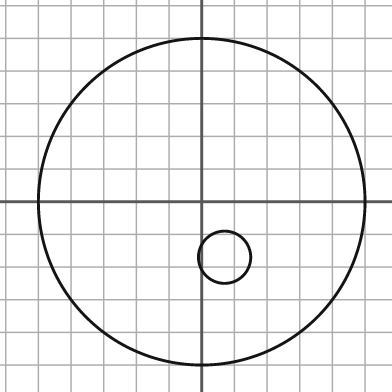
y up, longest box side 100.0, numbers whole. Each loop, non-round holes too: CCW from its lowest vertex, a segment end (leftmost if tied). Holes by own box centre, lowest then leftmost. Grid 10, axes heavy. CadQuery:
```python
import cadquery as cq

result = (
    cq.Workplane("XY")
    .moveTo(0.0, 0.0)
    .circle(50.0)
    .moveTo(7.0, -17.0)
    .circle(8.0)
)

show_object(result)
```